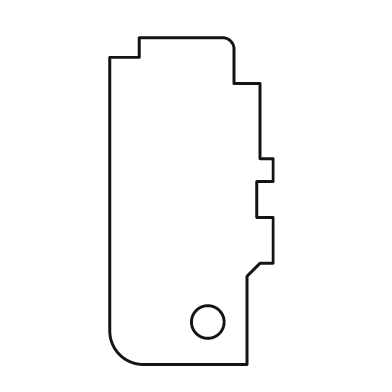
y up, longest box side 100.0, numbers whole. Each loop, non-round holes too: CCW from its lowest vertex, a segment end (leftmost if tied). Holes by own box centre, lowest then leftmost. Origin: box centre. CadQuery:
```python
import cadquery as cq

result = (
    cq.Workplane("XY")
    .moveTo(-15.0, -50.0)
    .lineTo(17.0, -50.0)
    .lineTo(17.0, -23.0)
    .lineTo(21.0, -19.0)
    .lineTo(25.0, -19.0)
    .lineTo(25.0, -5.0)
    .lineTo(20.0, -5.0)
    .lineTo(20.0, 6.0)
    .lineTo(25.0, 6.0)
    .lineTo(25.0, 13.0)
    .lineTo(21.0, 13.0)
    .lineTo(21.0, 36.0)
    .lineTo(13.0, 36.0)
    .lineTo(13.0, 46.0)
    .threePointArc((12.0, 49.0), (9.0, 50.0))
    .lineTo(-16.0, 50.0)
    .lineTo(-16.0, 44.0)
    .lineTo(-25.0, 44.0)
    .lineTo(-25.0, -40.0)
    .threePointArc((-22.0, -47.0), (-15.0, -50.0))
    .close()
    .moveTo(5.0, -37.0)
    .circle(5.0)
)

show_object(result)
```